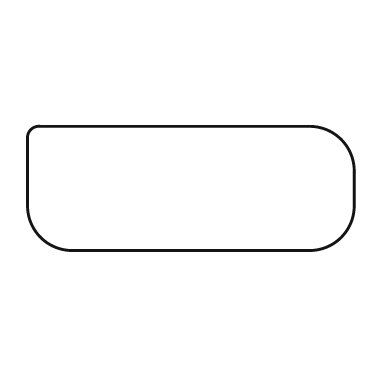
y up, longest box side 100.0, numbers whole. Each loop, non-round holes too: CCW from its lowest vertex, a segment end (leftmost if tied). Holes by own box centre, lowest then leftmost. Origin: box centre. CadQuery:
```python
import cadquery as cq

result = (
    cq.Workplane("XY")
    .moveTo(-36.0, -19.0)
    .lineTo(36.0, -19.0)
    .threePointArc((46.0, -15.0), (50.0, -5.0))
    .lineTo(50.0, 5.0)
    .threePointArc((46.0, 15.0), (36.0, 19.0))
    .lineTo(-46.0, 19.0)
    .threePointArc((-49.0, 18.0), (-50.0, 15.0))
    .lineTo(-50.0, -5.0)
    .threePointArc((-46.0, -15.0), (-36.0, -19.0))
    .close()
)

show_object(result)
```